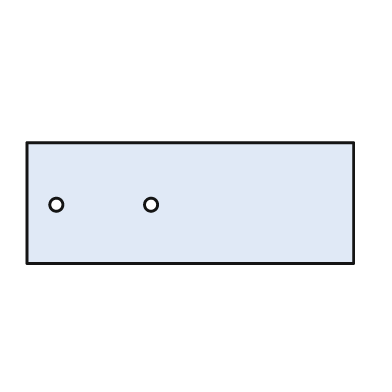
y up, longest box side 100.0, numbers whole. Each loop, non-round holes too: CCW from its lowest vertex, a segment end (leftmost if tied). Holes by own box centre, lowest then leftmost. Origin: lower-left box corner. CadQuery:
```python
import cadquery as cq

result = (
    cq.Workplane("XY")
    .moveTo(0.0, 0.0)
    .lineTo(100.0, 0.0)
    .lineTo(100.0, 37.0)
    .lineTo(0.0, 37.0)
    .close()
    .moveTo(9.0, 18.0)
    .circle(2.0)
    .moveTo(38.0, 18.0)
    .circle(2.0)
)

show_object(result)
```